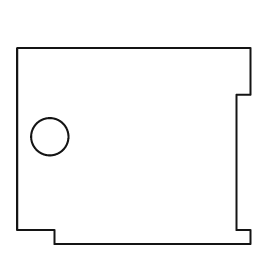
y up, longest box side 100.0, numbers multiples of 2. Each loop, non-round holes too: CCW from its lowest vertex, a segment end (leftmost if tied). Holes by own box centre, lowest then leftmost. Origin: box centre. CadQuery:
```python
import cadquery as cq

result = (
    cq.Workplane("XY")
    .moveTo(-34.0, -42.0)
    .lineTo(50.0, -42.0)
    .lineTo(50.0, -36.0)
    .lineTo(44.0, -36.0)
    .lineTo(44.0, 22.0)
    .lineTo(50.0, 22.0)
    .lineTo(50.0, 42.0)
    .lineTo(-50.0, 42.0)
    .lineTo(-50.0, -36.0)
    .lineTo(-34.0, -36.0)
    .close()
    .moveTo(-36.0, 4.0)
    .circle(8.0)
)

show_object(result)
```